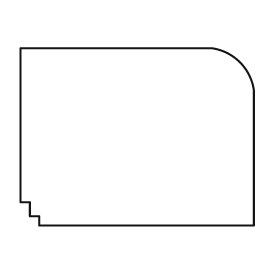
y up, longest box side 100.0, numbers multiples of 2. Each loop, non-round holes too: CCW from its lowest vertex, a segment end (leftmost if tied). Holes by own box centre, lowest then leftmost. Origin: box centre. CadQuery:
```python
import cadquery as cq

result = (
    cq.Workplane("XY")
    .moveTo(-42.0, -38.0)
    .lineTo(50.0, -38.0)
    .lineTo(50.0, 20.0)
    .threePointArc((44.0, 32.0), (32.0, 38.0))
    .lineTo(-50.0, 38.0)
    .lineTo(-50.0, -28.0)
    .lineTo(-46.0, -28.0)
    .lineTo(-46.0, -34.0)
    .lineTo(-42.0, -34.0)
    .close()
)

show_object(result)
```